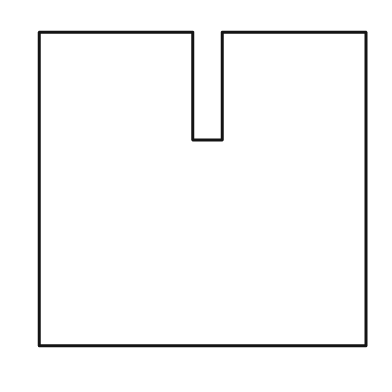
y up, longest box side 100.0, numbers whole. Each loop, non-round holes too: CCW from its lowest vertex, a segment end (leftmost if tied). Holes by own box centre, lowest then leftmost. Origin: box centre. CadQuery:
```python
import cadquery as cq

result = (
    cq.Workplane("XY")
    .moveTo(-50.0, -48.0)
    .lineTo(50.0, -48.0)
    .lineTo(50.0, 48.0)
    .lineTo(6.0, 48.0)
    .lineTo(6.0, 15.0)
    .lineTo(-3.0, 15.0)
    .lineTo(-3.0, 48.0)
    .lineTo(-50.0, 48.0)
    .close()
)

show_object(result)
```